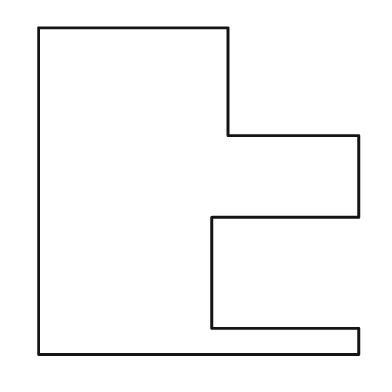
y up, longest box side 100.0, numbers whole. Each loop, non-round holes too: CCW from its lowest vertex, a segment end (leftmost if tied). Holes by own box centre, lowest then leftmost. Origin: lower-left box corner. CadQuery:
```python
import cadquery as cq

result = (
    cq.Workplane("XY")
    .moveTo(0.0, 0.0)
    .lineTo(98.0, 0.0)
    .lineTo(98.0, 8.0)
    .lineTo(53.0, 8.0)
    .lineTo(53.0, 42.0)
    .lineTo(98.0, 42.0)
    .lineTo(98.0, 67.0)
    .lineTo(58.0, 67.0)
    .lineTo(58.0, 100.0)
    .lineTo(0.0, 100.0)
    .close()
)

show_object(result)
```